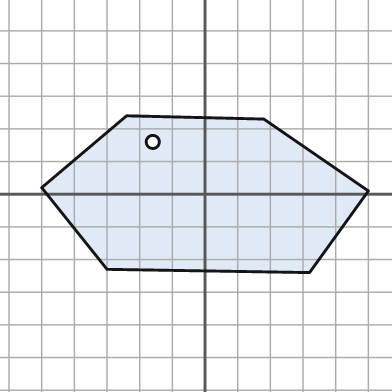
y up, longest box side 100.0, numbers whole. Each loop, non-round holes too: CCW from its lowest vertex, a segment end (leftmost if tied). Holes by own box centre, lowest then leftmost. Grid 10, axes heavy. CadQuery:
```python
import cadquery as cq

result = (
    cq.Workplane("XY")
    .moveTo(32.0, -24.0)
    .lineTo(50.0, 1.0)
    .lineTo(18.0, 23.0)
    .lineTo(-24.0, 24.0)
    .lineTo(-50.0, 2.0)
    .lineTo(-30.0, -23.0)
    .close()
    .moveTo(-16.0, 16.0)
    .circle(2.0)
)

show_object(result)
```